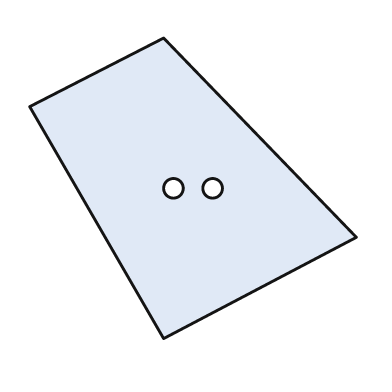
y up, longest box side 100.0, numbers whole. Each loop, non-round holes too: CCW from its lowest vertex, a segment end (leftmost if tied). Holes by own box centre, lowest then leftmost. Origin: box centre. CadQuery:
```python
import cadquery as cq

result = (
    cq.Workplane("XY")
    .moveTo(-9.0, -46.0)
    .lineTo(50.0, -15.0)
    .lineTo(-9.0, 46.0)
    .lineTo(-50.0, 25.0)
    .close()
    .moveTo(-6.0, 0.0)
    .circle(3.0)
    .moveTo(6.0, 0.0)
    .circle(3.0)
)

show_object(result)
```